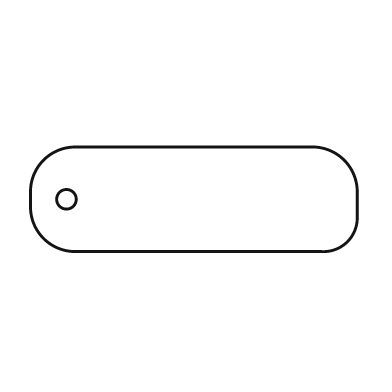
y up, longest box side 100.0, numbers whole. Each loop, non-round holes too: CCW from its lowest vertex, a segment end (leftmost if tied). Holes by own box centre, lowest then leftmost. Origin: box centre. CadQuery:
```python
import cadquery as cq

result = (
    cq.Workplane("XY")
    .moveTo(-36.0, -16.0)
    .lineTo(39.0, -16.0)
    .threePointArc((47.0, -13.0), (50.0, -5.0))
    .lineTo(50.0, 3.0)
    .threePointArc((46.0, 12.0), (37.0, 16.0))
    .lineTo(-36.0, 16.0)
    .threePointArc((-46.0, 12.0), (-50.0, 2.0))
    .lineTo(-50.0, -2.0)
    .threePointArc((-46.0, -12.0), (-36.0, -16.0))
    .close()
    .moveTo(-39.0, 0.0)
    .circle(3.0)
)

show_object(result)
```